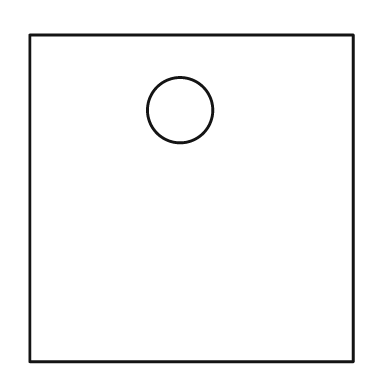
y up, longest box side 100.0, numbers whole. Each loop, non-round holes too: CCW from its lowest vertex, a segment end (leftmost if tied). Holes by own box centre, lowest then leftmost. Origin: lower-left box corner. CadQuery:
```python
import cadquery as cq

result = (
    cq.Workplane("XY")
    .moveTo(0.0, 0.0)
    .lineTo(99.0, 0.0)
    .lineTo(99.0, 100.0)
    .lineTo(0.0, 100.0)
    .close()
    .moveTo(46.0, 77.0)
    .circle(10.0)
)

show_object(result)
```